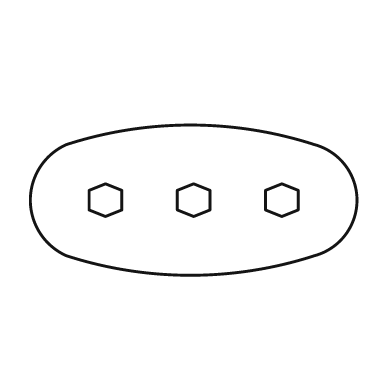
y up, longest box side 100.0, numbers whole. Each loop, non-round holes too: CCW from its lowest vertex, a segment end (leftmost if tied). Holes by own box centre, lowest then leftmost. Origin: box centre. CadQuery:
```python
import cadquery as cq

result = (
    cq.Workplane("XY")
    .moveTo(-39.0, -17.0)
    .threePointArc((-1.0, -23.0), (37.0, -17.0))
    .threePointArc((50.0, 0.0), (37.0, 17.0))
    .threePointArc((-1.0, 23.0), (-39.0, 17.0))
    .threePointArc((-50.0, 0.0), (-39.0, -17.0))
    .close()
    .moveTo(-27.0, -5.0)
    .lineTo(-22.0, -3.0)
    .lineTo(-22.0, 3.0)
    .lineTo(-27.0, 5.0)
    .lineTo(-32.0, 3.0)
    .lineTo(-32.0, -3.0)
    .close()
    .moveTo(0.0, -5.0)
    .lineTo(5.0, -3.0)
    .lineTo(5.0, 3.0)
    .lineTo(0.0, 5.0)
    .lineTo(-5.0, 3.0)
    .lineTo(-5.0, -3.0)
    .close()
    .moveTo(27.0, -5.0)
    .lineTo(32.0, -3.0)
    .lineTo(32.0, 3.0)
    .lineTo(27.0, 5.0)
    .lineTo(22.0, 3.0)
    .lineTo(22.0, -3.0)
    .close()
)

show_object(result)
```